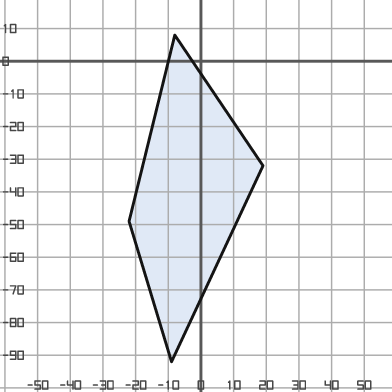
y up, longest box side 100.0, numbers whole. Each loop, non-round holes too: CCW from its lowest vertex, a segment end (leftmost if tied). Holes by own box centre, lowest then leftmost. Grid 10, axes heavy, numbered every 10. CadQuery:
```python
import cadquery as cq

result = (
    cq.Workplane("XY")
    .moveTo(-9.0, -92.0)
    .lineTo(19.0, -32.0)
    .lineTo(-8.0, 8.0)
    .lineTo(-22.0, -49.0)
    .close()
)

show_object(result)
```